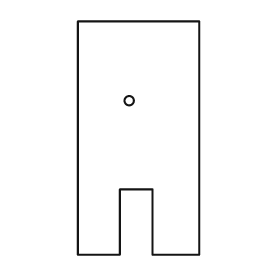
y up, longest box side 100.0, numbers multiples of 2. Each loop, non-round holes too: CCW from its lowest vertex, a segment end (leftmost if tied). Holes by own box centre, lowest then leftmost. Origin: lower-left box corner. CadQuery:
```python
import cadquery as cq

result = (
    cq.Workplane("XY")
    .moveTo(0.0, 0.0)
    .lineTo(18.0, 0.0)
    .lineTo(18.0, 28.0)
    .lineTo(32.0, 28.0)
    .lineTo(32.0, 0.0)
    .lineTo(52.0, 0.0)
    .lineTo(52.0, 100.0)
    .lineTo(0.0, 100.0)
    .close()
    .moveTo(22.0, 66.0)
    .circle(2.0)
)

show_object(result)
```